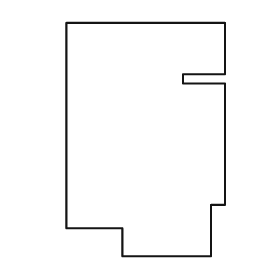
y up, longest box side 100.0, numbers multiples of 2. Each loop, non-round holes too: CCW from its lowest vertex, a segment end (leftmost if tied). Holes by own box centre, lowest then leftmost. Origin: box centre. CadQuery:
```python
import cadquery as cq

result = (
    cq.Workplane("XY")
    .moveTo(-10.0, -50.0)
    .lineTo(28.0, -50.0)
    .lineTo(28.0, -28.0)
    .lineTo(34.0, -28.0)
    .lineTo(34.0, 24.0)
    .lineTo(16.0, 24.0)
    .lineTo(16.0, 28.0)
    .lineTo(34.0, 28.0)
    .lineTo(34.0, 50.0)
    .lineTo(-34.0, 50.0)
    .lineTo(-34.0, -38.0)
    .lineTo(-10.0, -38.0)
    .close()
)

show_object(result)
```